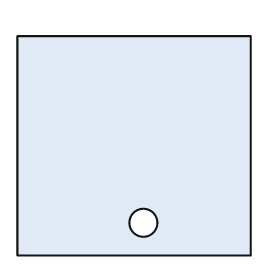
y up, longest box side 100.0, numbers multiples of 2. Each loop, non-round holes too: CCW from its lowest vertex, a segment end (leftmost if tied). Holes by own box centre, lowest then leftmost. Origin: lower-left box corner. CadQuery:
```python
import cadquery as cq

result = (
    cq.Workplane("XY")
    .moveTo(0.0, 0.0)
    .lineTo(100.0, 0.0)
    .lineTo(100.0, 94.0)
    .lineTo(0.0, 94.0)
    .close()
    .moveTo(54.0, 14.0)
    .circle(6.0)
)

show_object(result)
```